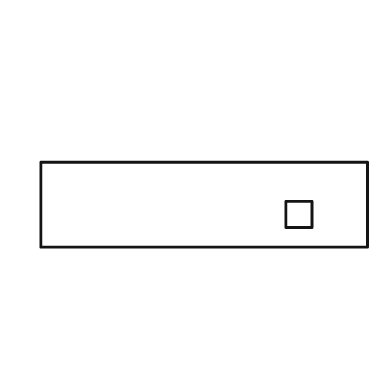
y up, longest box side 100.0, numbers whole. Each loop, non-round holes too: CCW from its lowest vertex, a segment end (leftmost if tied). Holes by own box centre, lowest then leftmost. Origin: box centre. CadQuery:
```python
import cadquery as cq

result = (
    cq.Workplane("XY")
    .moveTo(-50.0, -13.0)
    .lineTo(50.0, -13.0)
    .lineTo(50.0, 13.0)
    .lineTo(-50.0, 13.0)
    .close()
    .moveTo(25.0, -7.0)
    .lineTo(33.0, -7.0)
    .lineTo(33.0, 1.0)
    .lineTo(25.0, 1.0)
    .close()
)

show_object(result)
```